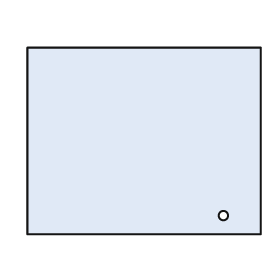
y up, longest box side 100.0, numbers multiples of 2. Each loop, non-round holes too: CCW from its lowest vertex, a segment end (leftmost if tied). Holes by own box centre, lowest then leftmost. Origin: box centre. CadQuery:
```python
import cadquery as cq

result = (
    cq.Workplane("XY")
    .moveTo(-50.0, -40.0)
    .lineTo(50.0, -40.0)
    .lineTo(50.0, 40.0)
    .lineTo(-50.0, 40.0)
    .close()
    .moveTo(34.0, -32.0)
    .circle(2.0)
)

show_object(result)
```